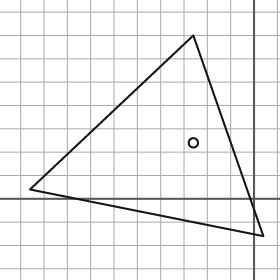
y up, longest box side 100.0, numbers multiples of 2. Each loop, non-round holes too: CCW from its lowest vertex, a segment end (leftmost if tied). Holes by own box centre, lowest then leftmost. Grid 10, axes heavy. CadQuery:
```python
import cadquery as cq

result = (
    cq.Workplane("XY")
    .moveTo(4.0, -16.0)
    .lineTo(-26.0, 70.0)
    .lineTo(-96.0, 4.0)
    .close()
    .moveTo(-26.0, 24.0)
    .circle(2.0)
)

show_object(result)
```